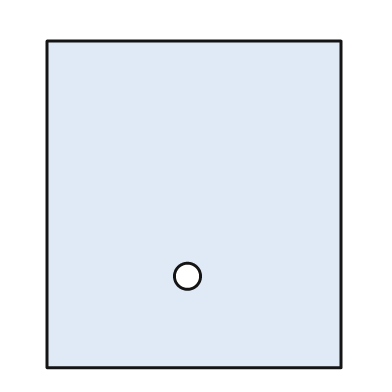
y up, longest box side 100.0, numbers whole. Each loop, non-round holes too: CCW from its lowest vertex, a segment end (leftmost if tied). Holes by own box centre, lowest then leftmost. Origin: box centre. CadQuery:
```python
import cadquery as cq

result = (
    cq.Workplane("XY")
    .moveTo(-45.0, -50.0)
    .lineTo(45.0, -50.0)
    .lineTo(45.0, 50.0)
    .lineTo(-45.0, 50.0)
    .close()
    .moveTo(-2.0, -22.0)
    .circle(4.0)
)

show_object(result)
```